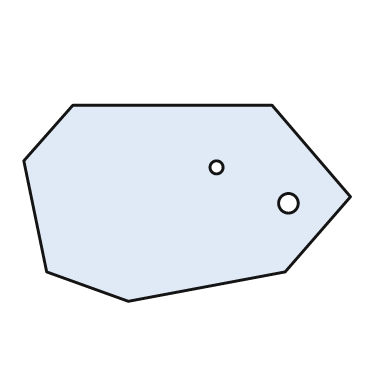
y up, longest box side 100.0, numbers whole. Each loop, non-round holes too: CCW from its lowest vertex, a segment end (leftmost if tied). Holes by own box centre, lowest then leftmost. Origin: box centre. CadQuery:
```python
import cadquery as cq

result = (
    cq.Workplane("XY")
    .moveTo(-18.0, -30.0)
    .lineTo(30.0, -21.0)
    .lineTo(50.0, 2.0)
    .lineTo(26.0, 30.0)
    .lineTo(-35.0, 30.0)
    .lineTo(-50.0, 13.0)
    .lineTo(-43.0, -21.0)
    .close()
    .moveTo(31.0, 0.0)
    .circle(3.0)
    .moveTo(9.0, 11.0)
    .circle(2.0)
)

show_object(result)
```